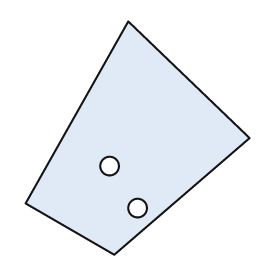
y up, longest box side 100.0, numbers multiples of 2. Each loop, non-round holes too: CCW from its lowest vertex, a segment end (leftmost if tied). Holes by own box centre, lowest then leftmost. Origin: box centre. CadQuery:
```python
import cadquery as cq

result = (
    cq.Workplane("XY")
    .moveTo(-10.0, -50.0)
    .lineTo(48.0, 0.0)
    .lineTo(-4.0, 50.0)
    .lineTo(-48.0, -28.0)
    .close()
    .moveTo(0.0, -30.0)
    .circle(4.0)
    .moveTo(-12.0, -12.0)
    .circle(4.0)
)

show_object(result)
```